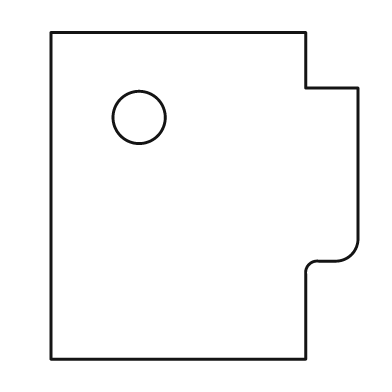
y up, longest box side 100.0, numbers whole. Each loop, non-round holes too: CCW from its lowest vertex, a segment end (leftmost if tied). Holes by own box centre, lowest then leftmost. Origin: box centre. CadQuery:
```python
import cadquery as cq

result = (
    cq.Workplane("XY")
    .moveTo(-47.0, -50.0)
    .lineTo(31.0, -50.0)
    .lineTo(31.0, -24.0)
    .threePointArc((32.0, -21.0), (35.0, -20.0))
    .lineTo(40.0, -20.0)
    .threePointArc((45.0, -18.0), (47.0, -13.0))
    .lineTo(47.0, 33.0)
    .lineTo(31.0, 33.0)
    .lineTo(31.0, 50.0)
    .lineTo(-47.0, 50.0)
    .close()
    .moveTo(-20.0, 24.0)
    .circle(8.0)
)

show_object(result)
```